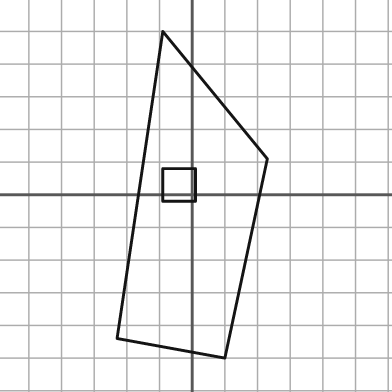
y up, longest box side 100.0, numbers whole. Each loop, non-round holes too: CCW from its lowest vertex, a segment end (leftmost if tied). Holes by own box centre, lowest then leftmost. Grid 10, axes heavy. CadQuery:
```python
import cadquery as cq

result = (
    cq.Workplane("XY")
    .moveTo(10.0, -50.0)
    .lineTo(23.0, 11.0)
    .lineTo(-9.0, 50.0)
    .lineTo(-23.0, -44.0)
    .close()
    .moveTo(-9.0, -2.0)
    .lineTo(1.0, -2.0)
    .lineTo(1.0, 8.0)
    .lineTo(-9.0, 8.0)
    .close()
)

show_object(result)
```